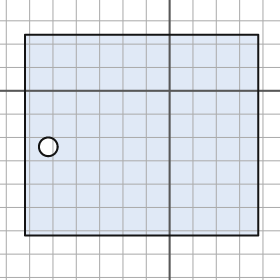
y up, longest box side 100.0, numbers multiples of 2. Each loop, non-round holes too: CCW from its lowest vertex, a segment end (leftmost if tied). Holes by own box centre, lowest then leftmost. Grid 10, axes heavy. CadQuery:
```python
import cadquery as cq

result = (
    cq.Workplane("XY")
    .moveTo(-62.0, -62.0)
    .lineTo(38.0, -62.0)
    .lineTo(38.0, 24.0)
    .lineTo(-62.0, 24.0)
    .close()
    .moveTo(-52.0, -24.0)
    .circle(4.0)
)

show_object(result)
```